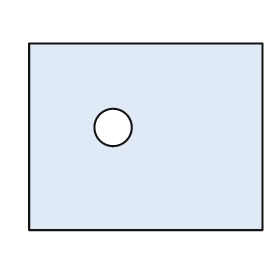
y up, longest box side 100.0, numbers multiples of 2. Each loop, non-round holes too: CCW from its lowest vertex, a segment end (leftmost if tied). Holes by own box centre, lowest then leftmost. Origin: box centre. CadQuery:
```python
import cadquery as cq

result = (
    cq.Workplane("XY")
    .moveTo(-50.0, -40.0)
    .lineTo(50.0, -40.0)
    .lineTo(50.0, 40.0)
    .lineTo(-50.0, 40.0)
    .close()
    .moveTo(-14.0, 4.0)
    .circle(8.0)
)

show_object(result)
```